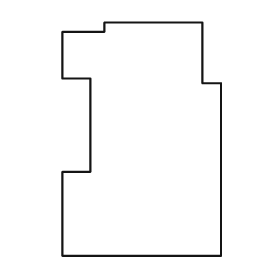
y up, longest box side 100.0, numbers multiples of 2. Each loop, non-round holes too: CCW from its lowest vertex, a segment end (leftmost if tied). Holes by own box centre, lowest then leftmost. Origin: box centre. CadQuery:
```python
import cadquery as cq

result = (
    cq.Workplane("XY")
    .moveTo(-34.0, -50.0)
    .lineTo(34.0, -50.0)
    .lineTo(34.0, 24.0)
    .lineTo(26.0, 24.0)
    .lineTo(26.0, 50.0)
    .lineTo(-16.0, 50.0)
    .lineTo(-16.0, 46.0)
    .lineTo(-34.0, 46.0)
    .lineTo(-34.0, 26.0)
    .lineTo(-22.0, 26.0)
    .lineTo(-22.0, -14.0)
    .lineTo(-34.0, -14.0)
    .close()
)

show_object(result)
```